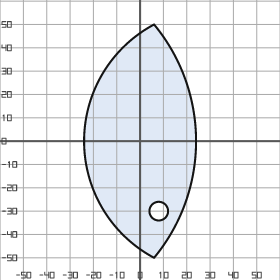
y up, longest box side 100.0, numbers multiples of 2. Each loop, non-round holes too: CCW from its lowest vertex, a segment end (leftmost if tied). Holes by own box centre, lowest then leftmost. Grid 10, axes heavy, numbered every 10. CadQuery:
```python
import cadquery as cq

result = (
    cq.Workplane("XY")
    .moveTo(6.0, -50.0)
    .threePointArc((24.0, 0.0), (6.0, 50.0))
    .threePointArc((-24.0, 0.0), (6.0, -50.0))
    .close()
    .moveTo(8.0, -30.0)
    .circle(4.0)
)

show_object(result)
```